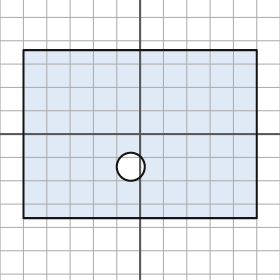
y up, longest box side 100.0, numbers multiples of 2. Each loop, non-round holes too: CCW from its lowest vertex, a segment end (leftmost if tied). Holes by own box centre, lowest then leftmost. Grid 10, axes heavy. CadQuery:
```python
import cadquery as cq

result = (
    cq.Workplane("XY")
    .moveTo(-50.0, -36.0)
    .lineTo(50.0, -36.0)
    .lineTo(50.0, 36.0)
    .lineTo(-50.0, 36.0)
    .close()
    .moveTo(-4.0, -14.0)
    .circle(6.0)
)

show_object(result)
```